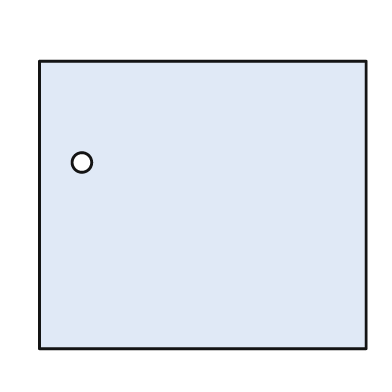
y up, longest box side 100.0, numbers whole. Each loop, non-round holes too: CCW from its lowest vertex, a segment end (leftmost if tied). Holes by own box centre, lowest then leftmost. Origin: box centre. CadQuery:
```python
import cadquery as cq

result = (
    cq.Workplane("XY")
    .moveTo(-50.0, -44.0)
    .lineTo(50.0, -44.0)
    .lineTo(50.0, 44.0)
    .lineTo(-50.0, 44.0)
    .close()
    .moveTo(-37.0, 13.0)
    .circle(3.0)
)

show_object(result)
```